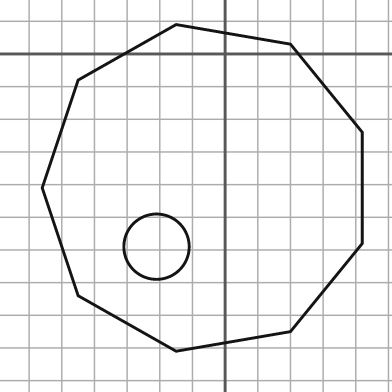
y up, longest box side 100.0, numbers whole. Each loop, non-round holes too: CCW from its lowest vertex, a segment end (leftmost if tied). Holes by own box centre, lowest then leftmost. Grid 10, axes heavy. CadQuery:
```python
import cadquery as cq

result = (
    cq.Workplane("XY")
    .moveTo(-15.0, -91.0)
    .lineTo(20.0, -85.0)
    .lineTo(42.0, -58.0)
    .lineTo(42.0, -24.0)
    .lineTo(20.0, 3.0)
    .lineTo(-15.0, 9.0)
    .lineTo(-45.0, -8.0)
    .lineTo(-56.0, -41.0)
    .lineTo(-45.0, -74.0)
    .close()
    .moveTo(-21.0, -59.0)
    .circle(10.0)
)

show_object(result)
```